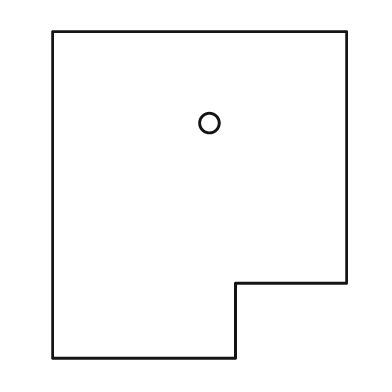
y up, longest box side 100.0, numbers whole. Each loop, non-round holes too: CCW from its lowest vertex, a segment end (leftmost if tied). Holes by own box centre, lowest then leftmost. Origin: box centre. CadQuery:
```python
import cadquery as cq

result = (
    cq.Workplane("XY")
    .moveTo(-45.0, -50.0)
    .lineTo(11.0, -50.0)
    .lineTo(11.0, -27.0)
    .lineTo(45.0, -27.0)
    .lineTo(45.0, 50.0)
    .lineTo(-45.0, 50.0)
    .close()
    .moveTo(3.0, 22.0)
    .circle(3.0)
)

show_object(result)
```